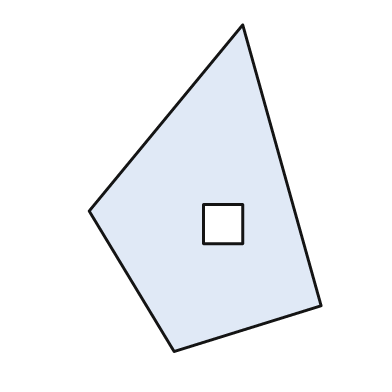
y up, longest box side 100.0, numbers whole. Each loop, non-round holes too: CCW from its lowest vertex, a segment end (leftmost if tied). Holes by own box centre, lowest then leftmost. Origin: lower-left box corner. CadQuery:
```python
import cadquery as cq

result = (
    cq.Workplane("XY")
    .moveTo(26.0, 0.0)
    .lineTo(71.0, 14.0)
    .lineTo(47.0, 100.0)
    .lineTo(0.0, 43.0)
    .close()
    .moveTo(35.0, 33.0)
    .lineTo(47.0, 33.0)
    .lineTo(47.0, 45.0)
    .lineTo(35.0, 45.0)
    .close()
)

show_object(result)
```